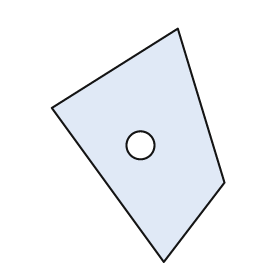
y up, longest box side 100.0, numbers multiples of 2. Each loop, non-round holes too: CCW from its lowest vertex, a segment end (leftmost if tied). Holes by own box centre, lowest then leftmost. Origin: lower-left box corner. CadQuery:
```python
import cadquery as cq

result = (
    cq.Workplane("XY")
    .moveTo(48.0, 0.0)
    .lineTo(74.0, 34.0)
    .lineTo(54.0, 100.0)
    .lineTo(0.0, 66.0)
    .close()
    .moveTo(38.0, 50.0)
    .circle(6.0)
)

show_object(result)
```